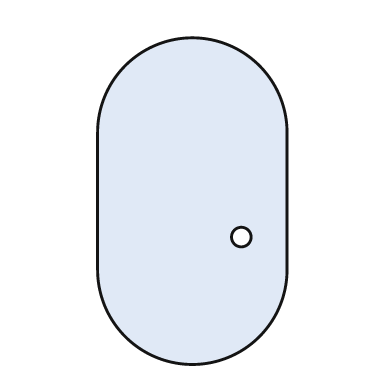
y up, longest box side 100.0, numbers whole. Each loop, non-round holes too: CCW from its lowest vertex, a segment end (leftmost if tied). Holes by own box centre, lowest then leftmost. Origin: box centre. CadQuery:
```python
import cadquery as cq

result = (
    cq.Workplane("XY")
    .moveTo(-29.0, -21.0)
    .threePointArc((0.0, -50.0), (29.0, -21.0))
    .lineTo(29.0, 21.0)
    .threePointArc((0.0, 50.0), (-29.0, 21.0))
    .close()
    .moveTo(15.0, -11.0)
    .circle(3.0)
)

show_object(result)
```